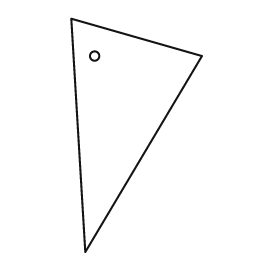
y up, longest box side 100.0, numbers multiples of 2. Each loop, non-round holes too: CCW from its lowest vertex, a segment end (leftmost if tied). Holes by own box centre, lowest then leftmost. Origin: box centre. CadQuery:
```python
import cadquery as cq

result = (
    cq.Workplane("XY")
    .moveTo(-22.0, -50.0)
    .lineTo(28.0, 34.0)
    .lineTo(-28.0, 50.0)
    .close()
    .moveTo(-18.0, 34.0)
    .circle(2.0)
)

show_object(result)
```